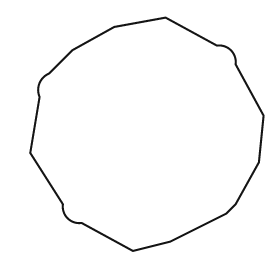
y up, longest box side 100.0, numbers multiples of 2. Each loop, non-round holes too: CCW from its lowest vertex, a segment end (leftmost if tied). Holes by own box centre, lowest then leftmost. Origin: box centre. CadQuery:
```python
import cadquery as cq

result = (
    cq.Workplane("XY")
    .moveTo(-6.0, -50.0)
    .lineTo(10.0, -46.0)
    .lineTo(34.0, -34.0)
    .lineTo(38.0, -30.0)
    .lineTo(48.0, -12.0)
    .lineTo(50.0, 8.0)
    .lineTo(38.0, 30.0)
    .threePointArc((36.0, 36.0), (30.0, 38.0))
    .lineTo(8.0, 50.0)
    .lineTo(-14.0, 46.0)
    .lineTo(-32.0, 36.0)
    .lineTo(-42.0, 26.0)
    .threePointArc((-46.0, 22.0), (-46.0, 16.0))
    .lineTo(-50.0, -8.0)
    .lineTo(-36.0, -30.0)
    .threePointArc((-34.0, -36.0), (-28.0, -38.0))
    .close()
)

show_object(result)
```